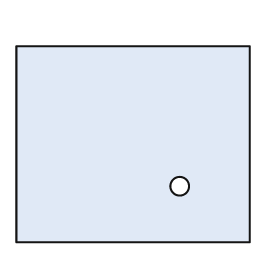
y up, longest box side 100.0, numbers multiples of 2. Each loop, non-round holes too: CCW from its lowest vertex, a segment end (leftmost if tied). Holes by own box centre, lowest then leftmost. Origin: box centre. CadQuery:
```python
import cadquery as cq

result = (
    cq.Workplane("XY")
    .moveTo(-50.0, -42.0)
    .lineTo(50.0, -42.0)
    .lineTo(50.0, 42.0)
    .lineTo(-50.0, 42.0)
    .close()
    .moveTo(20.0, -18.0)
    .circle(4.0)
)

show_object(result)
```